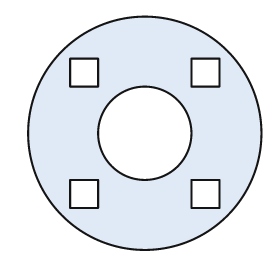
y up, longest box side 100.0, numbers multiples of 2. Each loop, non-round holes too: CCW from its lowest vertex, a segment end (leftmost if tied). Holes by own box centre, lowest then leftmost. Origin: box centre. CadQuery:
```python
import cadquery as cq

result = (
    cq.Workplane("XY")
    .moveTo(0.0, 0.0)
    .circle(50.0)
    .moveTo(-32.0, -32.0)
    .lineTo(-20.0, -32.0)
    .lineTo(-20.0, -20.0)
    .lineTo(-32.0, -20.0)
    .close()
    .moveTo(20.0, -32.0)
    .lineTo(32.0, -32.0)
    .lineTo(32.0, -20.0)
    .lineTo(20.0, -20.0)
    .close()
    .moveTo(0.0, 0.0)
    .circle(20.0)
    .moveTo(-32.0, 20.0)
    .lineTo(-20.0, 20.0)
    .lineTo(-20.0, 32.0)
    .lineTo(-32.0, 32.0)
    .close()
    .moveTo(20.0, 20.0)
    .lineTo(32.0, 20.0)
    .lineTo(32.0, 32.0)
    .lineTo(20.0, 32.0)
    .close()
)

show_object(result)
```